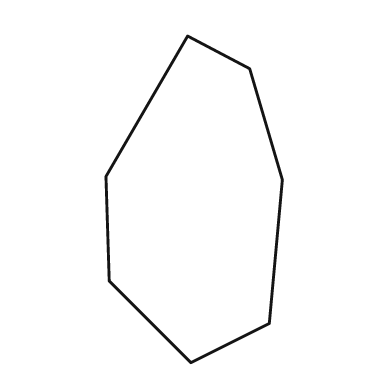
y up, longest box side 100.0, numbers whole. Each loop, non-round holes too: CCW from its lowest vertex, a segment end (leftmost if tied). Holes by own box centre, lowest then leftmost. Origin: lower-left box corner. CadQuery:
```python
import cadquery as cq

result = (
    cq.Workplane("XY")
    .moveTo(26.0, 0.0)
    .lineTo(50.0, 12.0)
    .lineTo(54.0, 56.0)
    .lineTo(44.0, 90.0)
    .lineTo(25.0, 100.0)
    .lineTo(0.0, 57.0)
    .lineTo(1.0, 25.0)
    .close()
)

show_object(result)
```